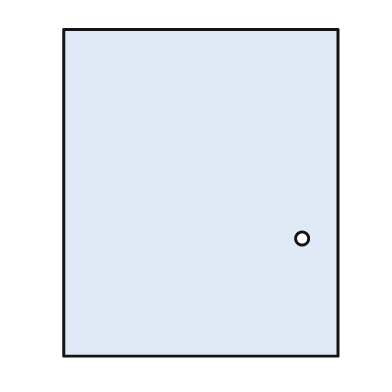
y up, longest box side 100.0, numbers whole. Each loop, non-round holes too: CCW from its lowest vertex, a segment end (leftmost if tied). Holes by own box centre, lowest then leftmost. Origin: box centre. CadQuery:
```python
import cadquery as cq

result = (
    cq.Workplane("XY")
    .moveTo(-42.0, -50.0)
    .lineTo(42.0, -50.0)
    .lineTo(42.0, 50.0)
    .lineTo(-42.0, 50.0)
    .close()
    .moveTo(31.0, -14.0)
    .circle(2.0)
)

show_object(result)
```